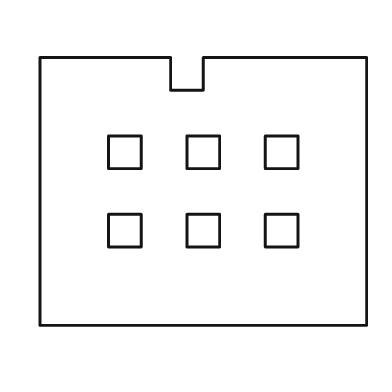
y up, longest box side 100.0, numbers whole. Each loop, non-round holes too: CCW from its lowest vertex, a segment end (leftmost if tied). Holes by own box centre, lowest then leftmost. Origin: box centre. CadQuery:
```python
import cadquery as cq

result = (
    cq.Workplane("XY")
    .moveTo(-50.0, -41.0)
    .lineTo(50.0, -41.0)
    .lineTo(50.0, 41.0)
    .lineTo(0.0, 41.0)
    .lineTo(0.0, 31.0)
    .lineTo(-10.0, 31.0)
    .lineTo(-10.0, 41.0)
    .lineTo(-50.0, 41.0)
    .close()
    .moveTo(-29.0, -17.0)
    .lineTo(-19.0, -17.0)
    .lineTo(-19.0, -7.0)
    .lineTo(-29.0, -7.0)
    .close()
    .moveTo(-5.0, -17.0)
    .lineTo(5.0, -17.0)
    .lineTo(5.0, -7.0)
    .lineTo(-5.0, -7.0)
    .close()
    .moveTo(19.0, -17.0)
    .lineTo(29.0, -17.0)
    .lineTo(29.0, -7.0)
    .lineTo(19.0, -7.0)
    .close()
    .moveTo(-29.0, 7.0)
    .lineTo(-19.0, 7.0)
    .lineTo(-19.0, 17.0)
    .lineTo(-29.0, 17.0)
    .close()
    .moveTo(-5.0, 7.0)
    .lineTo(5.0, 7.0)
    .lineTo(5.0, 17.0)
    .lineTo(-5.0, 17.0)
    .close()
    .moveTo(19.0, 7.0)
    .lineTo(29.0, 7.0)
    .lineTo(29.0, 17.0)
    .lineTo(19.0, 17.0)
    .close()
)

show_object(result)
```